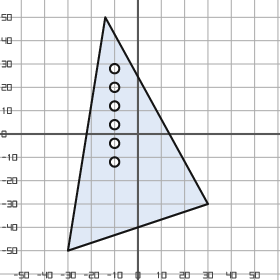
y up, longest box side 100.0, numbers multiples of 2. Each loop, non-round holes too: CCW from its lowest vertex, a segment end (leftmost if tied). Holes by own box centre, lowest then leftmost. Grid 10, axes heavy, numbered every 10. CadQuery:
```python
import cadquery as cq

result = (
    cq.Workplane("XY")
    .moveTo(-30.0, -50.0)
    .lineTo(30.0, -30.0)
    .lineTo(-14.0, 50.0)
    .close()
    .moveTo(-10.0, -12.0)
    .circle(2.0)
    .moveTo(-10.0, -4.0)
    .circle(2.0)
    .moveTo(-10.0, 4.0)
    .circle(2.0)
    .moveTo(-10.0, 12.0)
    .circle(2.0)
    .moveTo(-10.0, 20.0)
    .circle(2.0)
    .moveTo(-10.0, 28.0)
    .circle(2.0)
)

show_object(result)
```